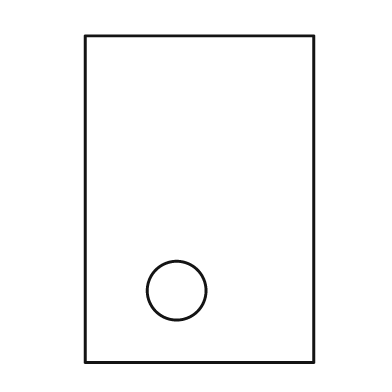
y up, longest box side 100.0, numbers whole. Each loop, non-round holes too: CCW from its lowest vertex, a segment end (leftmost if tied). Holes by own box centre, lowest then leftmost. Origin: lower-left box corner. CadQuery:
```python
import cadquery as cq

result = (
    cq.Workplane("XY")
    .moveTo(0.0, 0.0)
    .lineTo(70.0, 0.0)
    .lineTo(70.0, 100.0)
    .lineTo(0.0, 100.0)
    .close()
    .moveTo(28.0, 22.0)
    .circle(9.0)
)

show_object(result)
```